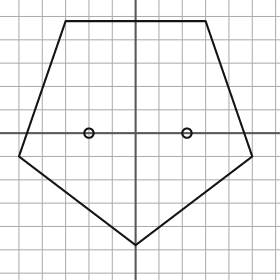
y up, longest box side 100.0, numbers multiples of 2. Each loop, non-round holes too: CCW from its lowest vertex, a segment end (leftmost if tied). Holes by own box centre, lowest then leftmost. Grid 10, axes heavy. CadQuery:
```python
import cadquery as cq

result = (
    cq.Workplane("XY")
    .moveTo(0.0, -48.0)
    .lineTo(50.0, -10.0)
    .lineTo(30.0, 48.0)
    .lineTo(-30.0, 48.0)
    .lineTo(-50.0, -10.0)
    .close()
    .moveTo(-20.0, 0.0)
    .circle(2.0)
    .moveTo(22.0, 0.0)
    .circle(2.0)
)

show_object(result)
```